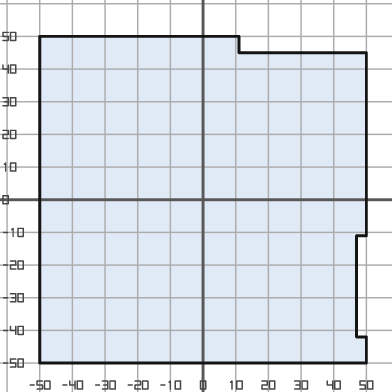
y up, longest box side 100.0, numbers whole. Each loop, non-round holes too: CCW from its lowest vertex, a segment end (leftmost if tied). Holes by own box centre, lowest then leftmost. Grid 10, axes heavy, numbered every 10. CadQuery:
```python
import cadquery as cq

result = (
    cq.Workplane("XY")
    .moveTo(-50.0, -50.0)
    .lineTo(50.0, -50.0)
    .lineTo(50.0, -42.0)
    .lineTo(47.0, -42.0)
    .lineTo(47.0, -11.0)
    .lineTo(50.0, -11.0)
    .lineTo(50.0, 45.0)
    .lineTo(11.0, 45.0)
    .lineTo(11.0, 50.0)
    .lineTo(-50.0, 50.0)
    .close()
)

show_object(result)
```